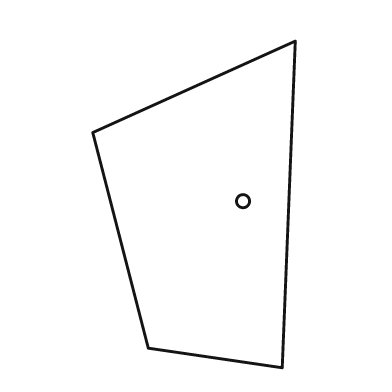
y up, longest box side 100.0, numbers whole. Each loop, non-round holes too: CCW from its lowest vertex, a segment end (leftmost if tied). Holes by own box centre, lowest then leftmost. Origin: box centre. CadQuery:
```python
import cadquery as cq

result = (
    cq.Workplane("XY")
    .moveTo(27.0, -50.0)
    .lineTo(31.0, 50.0)
    .lineTo(-31.0, 22.0)
    .lineTo(-14.0, -44.0)
    .close()
    .moveTo(15.0, 1.0)
    .circle(2.0)
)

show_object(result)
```